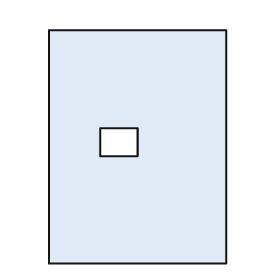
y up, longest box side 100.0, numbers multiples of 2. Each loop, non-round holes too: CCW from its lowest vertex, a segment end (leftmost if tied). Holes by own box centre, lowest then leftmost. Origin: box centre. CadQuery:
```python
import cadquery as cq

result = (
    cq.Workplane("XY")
    .moveTo(-38.0, -50.0)
    .lineTo(38.0, -50.0)
    .lineTo(38.0, 50.0)
    .lineTo(-38.0, 50.0)
    .close()
    .moveTo(-16.0, -4.0)
    .lineTo(0.0, -4.0)
    .lineTo(0.0, 8.0)
    .lineTo(-16.0, 8.0)
    .close()
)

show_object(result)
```